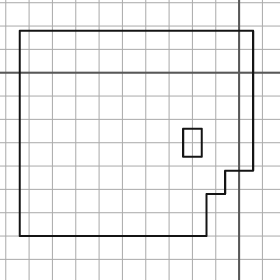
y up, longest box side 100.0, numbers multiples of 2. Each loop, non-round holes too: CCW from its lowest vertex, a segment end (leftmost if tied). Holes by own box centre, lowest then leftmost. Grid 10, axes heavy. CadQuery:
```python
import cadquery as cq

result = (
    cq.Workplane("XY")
    .moveTo(-94.0, -70.0)
    .lineTo(-14.0, -70.0)
    .lineTo(-14.0, -52.0)
    .lineTo(-6.0, -52.0)
    .lineTo(-6.0, -42.0)
    .lineTo(6.0, -42.0)
    .lineTo(6.0, 18.0)
    .lineTo(-94.0, 18.0)
    .close()
    .moveTo(-24.0, -36.0)
    .lineTo(-16.0, -36.0)
    .lineTo(-16.0, -24.0)
    .lineTo(-24.0, -24.0)
    .close()
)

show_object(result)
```